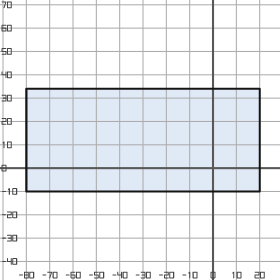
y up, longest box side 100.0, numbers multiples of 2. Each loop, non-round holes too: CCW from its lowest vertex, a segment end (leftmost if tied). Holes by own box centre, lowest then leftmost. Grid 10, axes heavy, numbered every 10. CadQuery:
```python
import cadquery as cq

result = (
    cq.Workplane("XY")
    .moveTo(-80.0, -10.0)
    .lineTo(20.0, -10.0)
    .lineTo(20.0, 34.0)
    .lineTo(-80.0, 34.0)
    .close()
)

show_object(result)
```